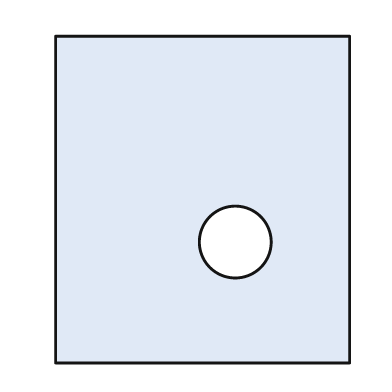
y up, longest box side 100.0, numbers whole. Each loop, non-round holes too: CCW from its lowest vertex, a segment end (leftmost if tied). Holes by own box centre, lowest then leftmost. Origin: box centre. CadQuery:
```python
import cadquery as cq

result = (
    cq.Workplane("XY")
    .moveTo(-45.0, -50.0)
    .lineTo(45.0, -50.0)
    .lineTo(45.0, 50.0)
    .lineTo(-45.0, 50.0)
    .close()
    .moveTo(10.0, -13.0)
    .circle(11.0)
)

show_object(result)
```